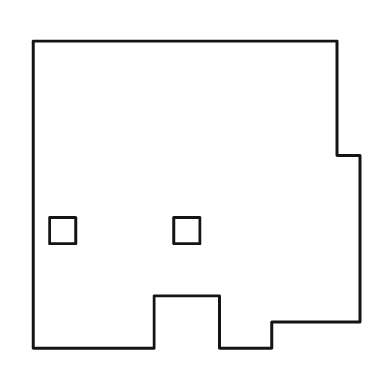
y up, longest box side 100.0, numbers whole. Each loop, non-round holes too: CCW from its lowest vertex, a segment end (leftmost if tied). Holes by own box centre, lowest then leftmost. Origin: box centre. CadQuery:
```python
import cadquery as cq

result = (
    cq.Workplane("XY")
    .moveTo(-50.0, -47.0)
    .lineTo(-13.0, -47.0)
    .lineTo(-13.0, -31.0)
    .lineTo(7.0, -31.0)
    .lineTo(7.0, -47.0)
    .lineTo(23.0, -47.0)
    .lineTo(23.0, -39.0)
    .lineTo(50.0, -39.0)
    .lineTo(50.0, 12.0)
    .lineTo(43.0, 12.0)
    .lineTo(43.0, 47.0)
    .lineTo(-50.0, 47.0)
    .close()
    .moveTo(-45.0, -15.0)
    .lineTo(-37.0, -15.0)
    .lineTo(-37.0, -7.0)
    .lineTo(-45.0, -7.0)
    .close()
    .moveTo(-7.0, -15.0)
    .lineTo(1.0, -15.0)
    .lineTo(1.0, -7.0)
    .lineTo(-7.0, -7.0)
    .close()
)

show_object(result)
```